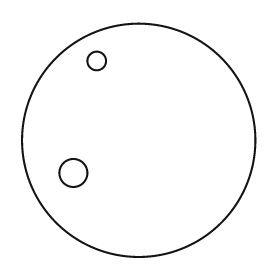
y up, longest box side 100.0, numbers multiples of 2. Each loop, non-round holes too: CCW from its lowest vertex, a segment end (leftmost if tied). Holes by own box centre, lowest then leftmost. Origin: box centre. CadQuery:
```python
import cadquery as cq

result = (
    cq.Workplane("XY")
    .moveTo(0.0, 0.0)
    .circle(50.0)
    .moveTo(-28.0, -14.0)
    .circle(6.0)
    .moveTo(-18.0, 34.0)
    .circle(4.0)
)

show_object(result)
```